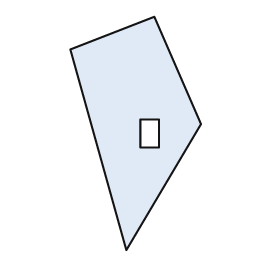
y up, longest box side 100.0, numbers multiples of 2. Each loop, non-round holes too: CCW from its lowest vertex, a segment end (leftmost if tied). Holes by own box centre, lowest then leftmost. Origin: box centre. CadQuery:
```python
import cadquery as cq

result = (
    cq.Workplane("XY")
    .moveTo(-4.0, -50.0)
    .lineTo(28.0, 4.0)
    .lineTo(8.0, 50.0)
    .lineTo(-28.0, 36.0)
    .close()
    .moveTo(2.0, -6.0)
    .lineTo(10.0, -6.0)
    .lineTo(10.0, 6.0)
    .lineTo(2.0, 6.0)
    .close()
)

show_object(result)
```